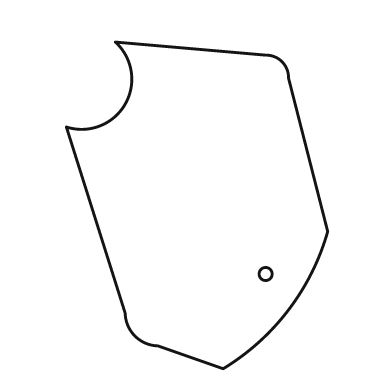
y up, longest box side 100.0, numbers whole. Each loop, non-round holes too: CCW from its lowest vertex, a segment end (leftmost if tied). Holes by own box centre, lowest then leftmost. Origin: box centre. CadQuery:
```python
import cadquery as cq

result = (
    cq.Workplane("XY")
    .moveTo(8.0, -50.0)
    .threePointArc((28.0, -32.0), (40.0, -8.0))
    .lineTo(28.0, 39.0)
    .threePointArc((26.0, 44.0), (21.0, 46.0))
    .lineTo(-25.0, 50.0)
    .threePointArc((-22.0, 31.0), (-40.0, 24.0))
    .lineTo(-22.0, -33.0)
    .threePointArc((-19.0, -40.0), (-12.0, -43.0))
    .close()
    .moveTo(21.0, -21.0)
    .circle(2.0)
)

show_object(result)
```